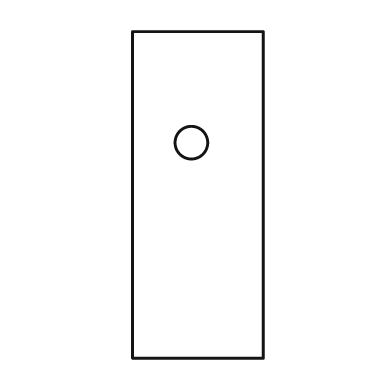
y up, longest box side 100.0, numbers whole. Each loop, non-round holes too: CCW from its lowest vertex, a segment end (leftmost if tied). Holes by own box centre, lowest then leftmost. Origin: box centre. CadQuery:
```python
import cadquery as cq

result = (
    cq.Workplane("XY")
    .moveTo(-20.0, -50.0)
    .lineTo(20.0, -50.0)
    .lineTo(20.0, 50.0)
    .lineTo(-20.0, 50.0)
    .close()
    .moveTo(-2.0, 16.0)
    .circle(5.0)
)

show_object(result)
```